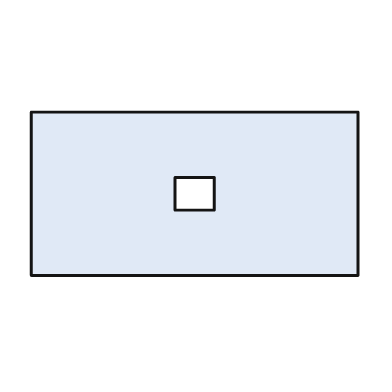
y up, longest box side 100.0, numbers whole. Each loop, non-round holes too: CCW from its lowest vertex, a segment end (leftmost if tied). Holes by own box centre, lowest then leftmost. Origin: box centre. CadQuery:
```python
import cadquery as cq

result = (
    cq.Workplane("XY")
    .moveTo(-50.0, -25.0)
    .lineTo(50.0, -25.0)
    .lineTo(50.0, 25.0)
    .lineTo(-50.0, 25.0)
    .close()
    .moveTo(-6.0, -5.0)
    .lineTo(6.0, -5.0)
    .lineTo(6.0, 5.0)
    .lineTo(-6.0, 5.0)
    .close()
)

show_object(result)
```